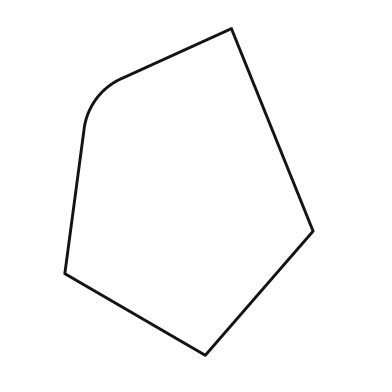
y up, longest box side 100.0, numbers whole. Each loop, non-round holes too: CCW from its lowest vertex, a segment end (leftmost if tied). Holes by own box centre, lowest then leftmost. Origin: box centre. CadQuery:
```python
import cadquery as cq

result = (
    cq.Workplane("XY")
    .moveTo(5.0, -50.0)
    .lineTo(38.0, -12.0)
    .lineTo(13.0, 50.0)
    .lineTo(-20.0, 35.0)
    .threePointArc((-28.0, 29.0), (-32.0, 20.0))
    .lineTo(-38.0, -25.0)
    .close()
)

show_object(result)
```